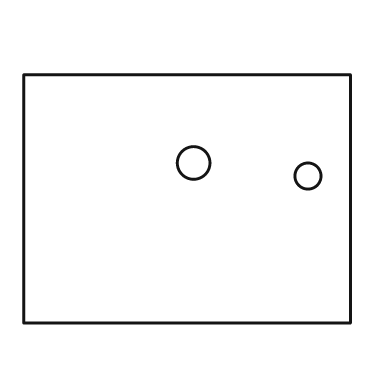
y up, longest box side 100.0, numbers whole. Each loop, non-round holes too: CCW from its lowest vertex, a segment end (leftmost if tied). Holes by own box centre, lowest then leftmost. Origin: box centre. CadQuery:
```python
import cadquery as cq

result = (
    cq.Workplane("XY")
    .moveTo(-50.0, -38.0)
    .lineTo(50.0, -38.0)
    .lineTo(50.0, 38.0)
    .lineTo(-50.0, 38.0)
    .close()
    .moveTo(37.0, 7.0)
    .circle(4.0)
    .moveTo(2.0, 11.0)
    .circle(5.0)
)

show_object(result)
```